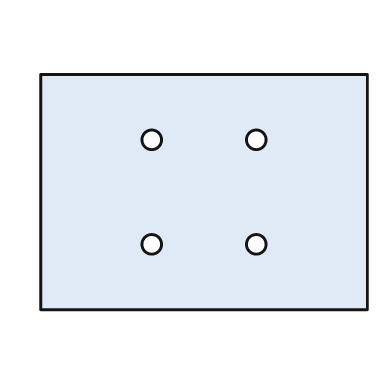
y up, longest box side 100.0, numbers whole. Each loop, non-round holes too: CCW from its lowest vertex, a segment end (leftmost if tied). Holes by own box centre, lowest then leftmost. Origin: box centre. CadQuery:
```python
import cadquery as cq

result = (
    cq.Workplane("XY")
    .moveTo(-50.0, -36.0)
    .lineTo(50.0, -36.0)
    .lineTo(50.0, 36.0)
    .lineTo(-50.0, 36.0)
    .close()
    .moveTo(-16.0, -16.0)
    .circle(3.0)
    .moveTo(16.0, -16.0)
    .circle(3.0)
    .moveTo(-16.0, 16.0)
    .circle(3.0)
    .moveTo(16.0, 16.0)
    .circle(3.0)
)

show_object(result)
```